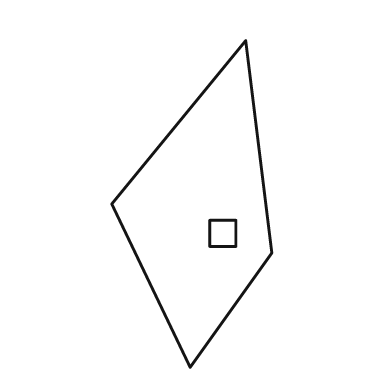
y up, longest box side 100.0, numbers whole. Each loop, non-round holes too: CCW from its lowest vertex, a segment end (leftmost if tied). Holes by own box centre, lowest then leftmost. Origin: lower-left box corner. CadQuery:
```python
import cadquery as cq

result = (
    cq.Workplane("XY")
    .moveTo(24.0, 0.0)
    .lineTo(49.0, 35.0)
    .lineTo(41.0, 100.0)
    .lineTo(0.0, 50.0)
    .close()
    .moveTo(30.0, 37.0)
    .lineTo(38.0, 37.0)
    .lineTo(38.0, 45.0)
    .lineTo(30.0, 45.0)
    .close()
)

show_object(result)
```